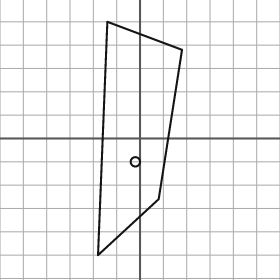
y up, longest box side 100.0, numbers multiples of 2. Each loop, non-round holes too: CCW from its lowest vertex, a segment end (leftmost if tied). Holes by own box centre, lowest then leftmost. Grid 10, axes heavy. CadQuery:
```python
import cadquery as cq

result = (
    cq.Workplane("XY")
    .moveTo(-18.0, -50.0)
    .lineTo(8.0, -26.0)
    .lineTo(18.0, 38.0)
    .lineTo(-14.0, 50.0)
    .close()
    .moveTo(-2.0, -10.0)
    .circle(2.0)
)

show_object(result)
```